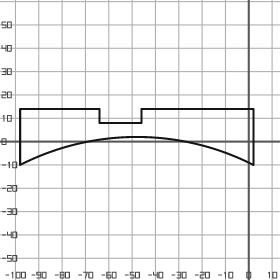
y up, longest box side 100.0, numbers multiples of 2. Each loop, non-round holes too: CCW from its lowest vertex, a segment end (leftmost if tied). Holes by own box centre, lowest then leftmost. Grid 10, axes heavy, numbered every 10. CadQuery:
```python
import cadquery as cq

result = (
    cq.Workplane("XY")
    .moveTo(-98.0, -10.0)
    .threePointArc((-48.0, 2.0), (2.0, -10.0))
    .lineTo(2.0, 14.0)
    .lineTo(-46.0, 14.0)
    .lineTo(-46.0, 8.0)
    .lineTo(-64.0, 8.0)
    .lineTo(-64.0, 14.0)
    .lineTo(-98.0, 14.0)
    .close()
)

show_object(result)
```